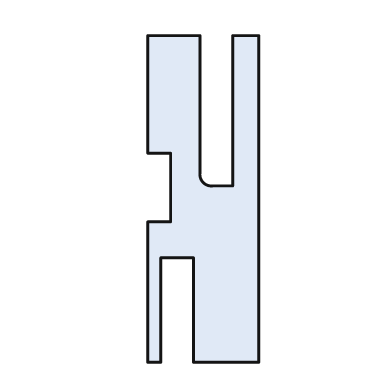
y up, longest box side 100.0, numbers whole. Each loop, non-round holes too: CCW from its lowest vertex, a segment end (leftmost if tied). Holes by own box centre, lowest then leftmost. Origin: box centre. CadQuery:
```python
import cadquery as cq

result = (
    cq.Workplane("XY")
    .moveTo(-17.0, -50.0)
    .lineTo(-13.0, -50.0)
    .lineTo(-13.0, -18.0)
    .lineTo(-3.0, -18.0)
    .lineTo(-3.0, -50.0)
    .lineTo(17.0, -50.0)
    .lineTo(17.0, 50.0)
    .lineTo(9.0, 50.0)
    .lineTo(9.0, 4.0)
    .lineTo(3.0, 4.0)
    .threePointArc((0.0, 5.0), (-1.0, 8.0))
    .lineTo(-1.0, 50.0)
    .lineTo(-17.0, 50.0)
    .lineTo(-17.0, 14.0)
    .lineTo(-10.0, 14.0)
    .lineTo(-10.0, -7.0)
    .lineTo(-17.0, -7.0)
    .close()
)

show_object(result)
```